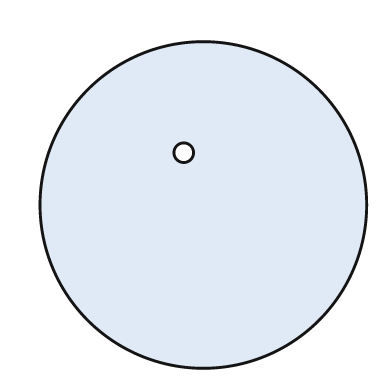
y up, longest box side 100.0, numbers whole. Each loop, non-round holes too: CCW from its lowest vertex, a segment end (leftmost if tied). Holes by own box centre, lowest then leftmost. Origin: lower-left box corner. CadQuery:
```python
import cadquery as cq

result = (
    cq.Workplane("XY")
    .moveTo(50.0, 50.0)
    .circle(50.0)
    .moveTo(44.0, 66.0)
    .circle(3.0)
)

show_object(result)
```